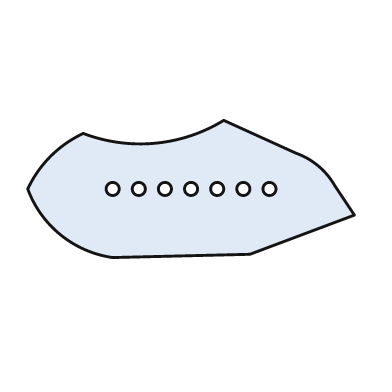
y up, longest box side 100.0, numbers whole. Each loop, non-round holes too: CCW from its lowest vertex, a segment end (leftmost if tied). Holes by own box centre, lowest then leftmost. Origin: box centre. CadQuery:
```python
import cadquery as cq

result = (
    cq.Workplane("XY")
    .moveTo(-24.0, -21.0)
    .lineTo(18.0, -20.0)
    .lineTo(50.0, -8.0)
    .lineTo(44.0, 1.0)
    .threePointArc((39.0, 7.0), (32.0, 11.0))
    .lineTo(10.0, 21.0)
    .threePointArc((-11.0, 14.0), (-33.0, 17.0))
    .threePointArc((-43.0, 10.0), (-50.0, 0.0))
    .threePointArc((-40.0, -14.0), (-24.0, -21.0))
    .close()
    .moveTo(-24.0, 0.0)
    .circle(2.0)
    .moveTo(-16.0, 0.0)
    .circle(2.0)
    .moveTo(-8.0, 0.0)
    .circle(2.0)
    .moveTo(0.0, 0.0)
    .circle(2.0)
    .moveTo(8.0, 0.0)
    .circle(2.0)
    .moveTo(16.0, 0.0)
    .circle(2.0)
    .moveTo(24.0, 0.0)
    .circle(2.0)
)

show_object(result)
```